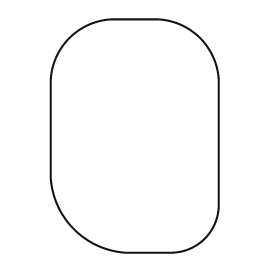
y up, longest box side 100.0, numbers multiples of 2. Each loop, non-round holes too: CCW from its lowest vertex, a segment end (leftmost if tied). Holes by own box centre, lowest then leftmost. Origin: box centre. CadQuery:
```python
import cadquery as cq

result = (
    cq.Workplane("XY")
    .moveTo(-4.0, -50.0)
    .lineTo(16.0, -50.0)
    .threePointArc((30.0, -44.0), (36.0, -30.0))
    .lineTo(36.0, 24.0)
    .threePointArc((28.0, 42.0), (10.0, 50.0))
    .lineTo(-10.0, 50.0)
    .threePointArc((-28.0, 42.0), (-36.0, 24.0))
    .lineTo(-36.0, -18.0)
    .threePointArc((-26.0, -40.0), (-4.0, -50.0))
    .close()
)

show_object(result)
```